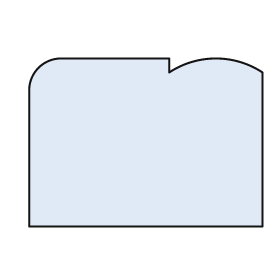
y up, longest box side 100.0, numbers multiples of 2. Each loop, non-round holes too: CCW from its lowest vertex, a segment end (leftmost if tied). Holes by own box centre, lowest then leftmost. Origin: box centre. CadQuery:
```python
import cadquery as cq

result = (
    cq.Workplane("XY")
    .moveTo(-50.0, -36.0)
    .lineTo(50.0, -36.0)
    .lineTo(50.0, 30.0)
    .threePointArc((30.0, 36.0), (10.0, 30.0))
    .lineTo(10.0, 36.0)
    .lineTo(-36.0, 36.0)
    .threePointArc((-46.0, 32.0), (-50.0, 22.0))
    .close()
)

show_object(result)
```